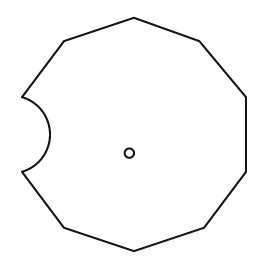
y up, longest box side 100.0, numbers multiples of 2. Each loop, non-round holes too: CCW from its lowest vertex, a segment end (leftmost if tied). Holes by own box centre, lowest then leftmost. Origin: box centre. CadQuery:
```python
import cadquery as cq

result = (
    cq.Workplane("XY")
    .moveTo(0.0, -50.0)
    .lineTo(30.0, -40.0)
    .lineTo(48.0, -16.0)
    .lineTo(48.0, 16.0)
    .lineTo(28.0, 40.0)
    .lineTo(0.0, 50.0)
    .lineTo(-30.0, 40.0)
    .lineTo(-48.0, 16.0)
    .threePointArc((-36.0, 0.0), (-48.0, -16.0))
    .lineTo(-30.0, -40.0)
    .close()
    .moveTo(-2.0, -8.0)
    .circle(2.0)
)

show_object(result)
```